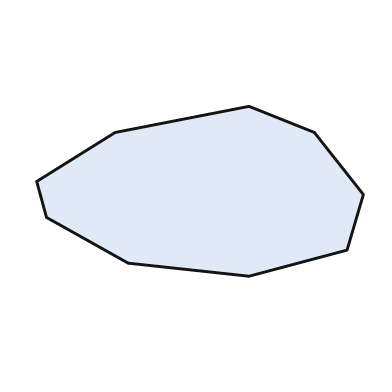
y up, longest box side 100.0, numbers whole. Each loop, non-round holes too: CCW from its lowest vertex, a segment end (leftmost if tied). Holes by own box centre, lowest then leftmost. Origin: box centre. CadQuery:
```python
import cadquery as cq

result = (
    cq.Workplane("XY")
    .moveTo(15.0, -26.0)
    .lineTo(45.0, -18.0)
    .lineTo(50.0, -1.0)
    .lineTo(35.0, 18.0)
    .lineTo(15.0, 26.0)
    .lineTo(-26.0, 18.0)
    .lineTo(-50.0, 3.0)
    .lineTo(-47.0, -8.0)
    .lineTo(-22.0, -22.0)
    .close()
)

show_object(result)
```